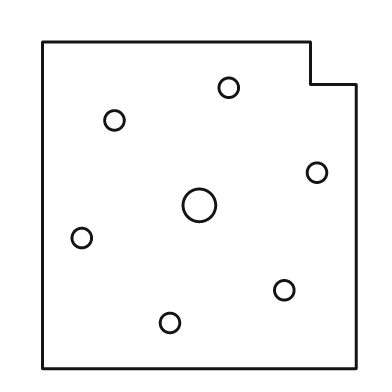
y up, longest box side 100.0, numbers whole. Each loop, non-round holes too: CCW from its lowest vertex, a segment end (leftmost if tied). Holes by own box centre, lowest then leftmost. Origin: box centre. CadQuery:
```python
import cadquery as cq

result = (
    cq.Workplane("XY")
    .moveTo(-48.0, -50.0)
    .lineTo(48.0, -50.0)
    .lineTo(48.0, 37.0)
    .lineTo(34.0, 37.0)
    .lineTo(34.0, 50.0)
    .lineTo(-48.0, 50.0)
    .close()
    .moveTo(-9.0, -36.0)
    .circle(3.0)
    .moveTo(26.0, -26.0)
    .circle(3.0)
    .moveTo(-36.0, -10.0)
    .circle(3.0)
    .moveTo(0.0, 0.0)
    .circle(5.0)
    .moveTo(36.0, 10.0)
    .circle(3.0)
    .moveTo(-26.0, 26.0)
    .circle(3.0)
    .moveTo(9.0, 36.0)
    .circle(3.0)
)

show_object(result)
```